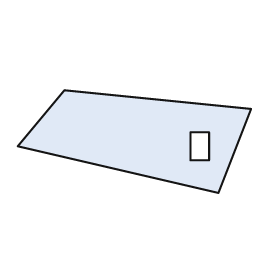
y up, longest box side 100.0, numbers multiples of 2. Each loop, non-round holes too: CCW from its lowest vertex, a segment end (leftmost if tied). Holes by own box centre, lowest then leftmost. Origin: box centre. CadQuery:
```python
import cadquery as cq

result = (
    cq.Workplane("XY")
    .moveTo(36.0, -22.0)
    .lineTo(50.0, 14.0)
    .lineTo(-30.0, 22.0)
    .lineTo(-50.0, -2.0)
    .close()
    .moveTo(24.0, -8.0)
    .lineTo(32.0, -8.0)
    .lineTo(32.0, 4.0)
    .lineTo(24.0, 4.0)
    .close()
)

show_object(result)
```